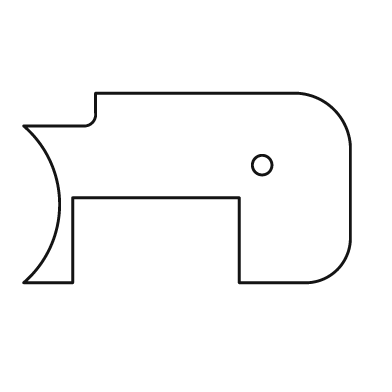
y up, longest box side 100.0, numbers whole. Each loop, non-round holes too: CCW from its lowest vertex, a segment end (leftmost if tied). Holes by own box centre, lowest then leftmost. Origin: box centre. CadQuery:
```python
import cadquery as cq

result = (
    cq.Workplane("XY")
    .moveTo(-50.0, -29.0)
    .lineTo(-35.0, -29.0)
    .lineTo(-35.0, -3.0)
    .lineTo(16.0, -3.0)
    .lineTo(16.0, -29.0)
    .lineTo(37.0, -29.0)
    .threePointArc((46.0, -25.0), (50.0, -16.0))
    .lineTo(50.0, 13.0)
    .threePointArc((45.0, 24.0), (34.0, 29.0))
    .lineTo(-28.0, 29.0)
    .lineTo(-28.0, 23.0)
    .threePointArc((-29.0, 20.0), (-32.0, 19.0))
    .lineTo(-50.0, 19.0)
    .threePointArc((-39.0, -5.0), (-50.0, -29.0))
    .close()
    .moveTo(23.0, 7.0)
    .circle(3.0)
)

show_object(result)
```